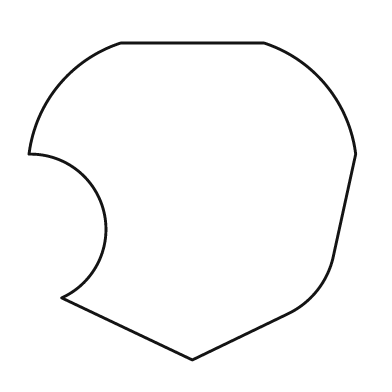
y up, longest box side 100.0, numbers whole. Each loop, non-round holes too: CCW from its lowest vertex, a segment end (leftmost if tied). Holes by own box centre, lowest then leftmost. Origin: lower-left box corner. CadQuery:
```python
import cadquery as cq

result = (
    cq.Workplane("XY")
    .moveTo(50.0, 0.0)
    .lineTo(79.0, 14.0)
    .threePointArc((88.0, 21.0), (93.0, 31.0))
    .lineTo(100.0, 63.0)
    .threePointArc((91.0, 84.0), (72.0, 97.0))
    .lineTo(28.0, 97.0)
    .threePointArc((9.0, 84.0), (0.0, 63.0))
    .threePointArc((23.0, 45.0), (10.0, 19.0))
    .close()
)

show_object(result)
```